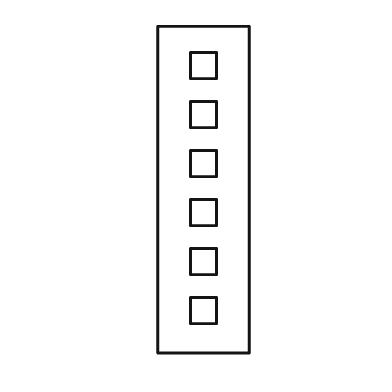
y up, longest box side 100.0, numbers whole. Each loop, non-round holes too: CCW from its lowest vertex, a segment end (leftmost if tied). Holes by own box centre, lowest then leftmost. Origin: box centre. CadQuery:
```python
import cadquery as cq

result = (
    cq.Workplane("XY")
    .moveTo(-14.0, -50.0)
    .lineTo(14.0, -50.0)
    .lineTo(14.0, 50.0)
    .lineTo(-14.0, 50.0)
    .close()
    .moveTo(-4.0, -41.0)
    .lineTo(4.0, -41.0)
    .lineTo(4.0, -33.0)
    .lineTo(-4.0, -33.0)
    .close()
    .moveTo(-4.0, -26.0)
    .lineTo(4.0, -26.0)
    .lineTo(4.0, -18.0)
    .lineTo(-4.0, -18.0)
    .close()
    .moveTo(-4.0, -11.0)
    .lineTo(4.0, -11.0)
    .lineTo(4.0, -3.0)
    .lineTo(-4.0, -3.0)
    .close()
    .moveTo(-4.0, 4.0)
    .lineTo(4.0, 4.0)
    .lineTo(4.0, 12.0)
    .lineTo(-4.0, 12.0)
    .close()
    .moveTo(-4.0, 19.0)
    .lineTo(4.0, 19.0)
    .lineTo(4.0, 27.0)
    .lineTo(-4.0, 27.0)
    .close()
    .moveTo(-4.0, 34.0)
    .lineTo(4.0, 34.0)
    .lineTo(4.0, 42.0)
    .lineTo(-4.0, 42.0)
    .close()
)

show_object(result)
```